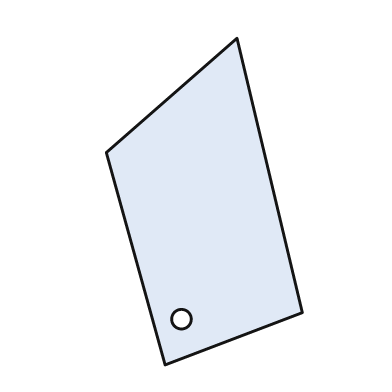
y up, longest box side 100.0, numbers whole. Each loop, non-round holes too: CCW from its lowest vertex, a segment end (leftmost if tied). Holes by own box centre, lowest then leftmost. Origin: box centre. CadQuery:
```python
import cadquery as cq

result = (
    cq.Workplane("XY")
    .moveTo(-12.0, -50.0)
    .lineTo(30.0, -34.0)
    .lineTo(10.0, 50.0)
    .lineTo(-30.0, 15.0)
    .close()
    .moveTo(-7.0, -36.0)
    .circle(3.0)
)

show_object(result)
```